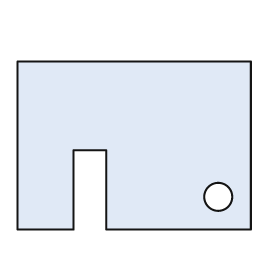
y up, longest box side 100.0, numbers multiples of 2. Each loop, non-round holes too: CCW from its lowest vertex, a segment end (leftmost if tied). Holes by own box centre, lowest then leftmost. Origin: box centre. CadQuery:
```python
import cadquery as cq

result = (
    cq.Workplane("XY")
    .moveTo(-50.0, -36.0)
    .lineTo(-26.0, -36.0)
    .lineTo(-26.0, -2.0)
    .lineTo(-12.0, -2.0)
    .lineTo(-12.0, -36.0)
    .lineTo(50.0, -36.0)
    .lineTo(50.0, 36.0)
    .lineTo(-50.0, 36.0)
    .close()
    .moveTo(36.0, -22.0)
    .circle(6.0)
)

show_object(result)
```